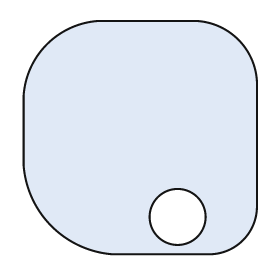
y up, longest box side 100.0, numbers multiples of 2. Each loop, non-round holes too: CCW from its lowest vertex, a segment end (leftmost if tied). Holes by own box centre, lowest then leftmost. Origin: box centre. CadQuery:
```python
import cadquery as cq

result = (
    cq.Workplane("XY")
    .moveTo(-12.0, -50.0)
    .lineTo(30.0, -50.0)
    .threePointArc((44.0, -44.0), (50.0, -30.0))
    .lineTo(50.0, 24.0)
    .threePointArc((42.0, 42.0), (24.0, 50.0))
    .lineTo(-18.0, 50.0)
    .threePointArc((-40.0, 40.0), (-50.0, 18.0))
    .lineTo(-50.0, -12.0)
    .threePointArc((-38.0, -38.0), (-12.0, -50.0))
    .close()
    .moveTo(16.0, -34.0)
    .circle(12.0)
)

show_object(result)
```